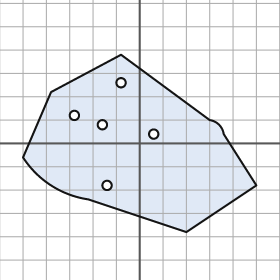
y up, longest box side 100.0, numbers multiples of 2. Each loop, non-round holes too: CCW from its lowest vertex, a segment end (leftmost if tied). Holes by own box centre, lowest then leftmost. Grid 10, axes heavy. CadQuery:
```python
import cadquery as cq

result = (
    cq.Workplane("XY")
    .moveTo(20.0, -38.0)
    .lineTo(50.0, -18.0)
    .lineTo(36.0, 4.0)
    .threePointArc((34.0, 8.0), (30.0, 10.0))
    .lineTo(-8.0, 38.0)
    .lineTo(-38.0, 22.0)
    .lineTo(-50.0, -6.0)
    .threePointArc((-38.0, -18.0), (-22.0, -24.0))
    .close()
    .moveTo(-14.0, -18.0)
    .circle(2.0)
    .moveTo(6.0, 4.0)
    .circle(2.0)
    .moveTo(-16.0, 8.0)
    .circle(2.0)
    .moveTo(-28.0, 12.0)
    .circle(2.0)
    .moveTo(-8.0, 26.0)
    .circle(2.0)
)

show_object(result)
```